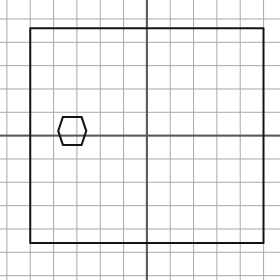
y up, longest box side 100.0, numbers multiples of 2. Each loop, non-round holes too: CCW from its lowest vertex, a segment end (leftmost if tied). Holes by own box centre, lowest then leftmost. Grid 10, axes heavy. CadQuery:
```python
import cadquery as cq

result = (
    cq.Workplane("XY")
    .moveTo(-50.0, -46.0)
    .lineTo(50.0, -46.0)
    .lineTo(50.0, 46.0)
    .lineTo(-50.0, 46.0)
    .close()
    .moveTo(-36.0, -4.0)
    .lineTo(-28.0, -4.0)
    .lineTo(-26.0, 2.0)
    .lineTo(-28.0, 8.0)
    .lineTo(-36.0, 8.0)
    .lineTo(-38.0, 2.0)
    .close()
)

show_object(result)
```